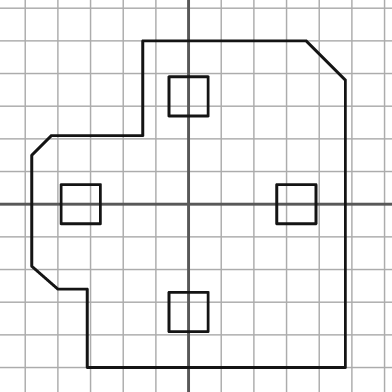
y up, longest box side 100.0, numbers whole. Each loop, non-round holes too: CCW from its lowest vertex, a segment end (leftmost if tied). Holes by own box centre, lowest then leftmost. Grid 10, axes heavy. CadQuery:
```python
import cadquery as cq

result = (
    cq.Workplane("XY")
    .moveTo(-31.0, -50.0)
    .lineTo(48.0, -50.0)
    .lineTo(48.0, 38.0)
    .lineTo(36.0, 50.0)
    .lineTo(-14.0, 50.0)
    .lineTo(-14.0, 21.0)
    .lineTo(-42.0, 21.0)
    .lineTo(-48.0, 15.0)
    .lineTo(-48.0, -19.0)
    .lineTo(-40.0, -26.0)
    .lineTo(-31.0, -26.0)
    .close()
    .moveTo(-6.0, -39.0)
    .lineTo(6.0, -39.0)
    .lineTo(6.0, -27.0)
    .lineTo(-6.0, -27.0)
    .close()
    .moveTo(-39.0, -6.0)
    .lineTo(-27.0, -6.0)
    .lineTo(-27.0, 6.0)
    .lineTo(-39.0, 6.0)
    .close()
    .moveTo(27.0, -6.0)
    .lineTo(39.0, -6.0)
    .lineTo(39.0, 6.0)
    .lineTo(27.0, 6.0)
    .close()
    .moveTo(-6.0, 27.0)
    .lineTo(6.0, 27.0)
    .lineTo(6.0, 39.0)
    .lineTo(-6.0, 39.0)
    .close()
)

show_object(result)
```